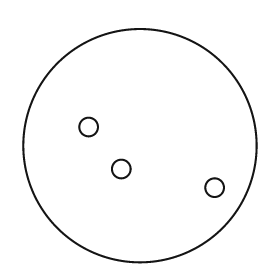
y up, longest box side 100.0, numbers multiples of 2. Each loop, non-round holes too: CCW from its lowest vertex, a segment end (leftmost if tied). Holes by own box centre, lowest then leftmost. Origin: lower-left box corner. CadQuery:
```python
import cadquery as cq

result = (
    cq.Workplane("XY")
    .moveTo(50.0, 50.0)
    .circle(50.0)
    .moveTo(82.0, 32.0)
    .circle(4.0)
    .moveTo(42.0, 40.0)
    .circle(4.0)
    .moveTo(28.0, 58.0)
    .circle(4.0)
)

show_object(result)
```